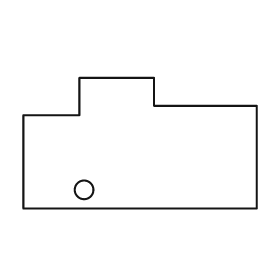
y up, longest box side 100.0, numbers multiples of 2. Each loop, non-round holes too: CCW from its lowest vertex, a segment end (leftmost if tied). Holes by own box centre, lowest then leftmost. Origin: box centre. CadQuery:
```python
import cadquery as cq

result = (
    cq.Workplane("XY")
    .moveTo(-50.0, -28.0)
    .lineTo(50.0, -28.0)
    .lineTo(50.0, 16.0)
    .lineTo(6.0, 16.0)
    .lineTo(6.0, 28.0)
    .lineTo(-26.0, 28.0)
    .lineTo(-26.0, 12.0)
    .lineTo(-50.0, 12.0)
    .close()
    .moveTo(-24.0, -20.0)
    .circle(4.0)
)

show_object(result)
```